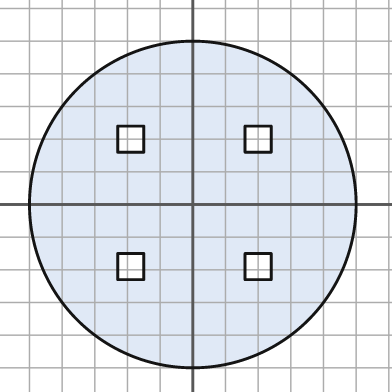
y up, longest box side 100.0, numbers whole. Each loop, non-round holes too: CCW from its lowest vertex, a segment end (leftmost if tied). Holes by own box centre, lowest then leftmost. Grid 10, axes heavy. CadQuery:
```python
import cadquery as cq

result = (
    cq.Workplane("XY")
    .moveTo(0.0, 0.0)
    .circle(50.0)
    .moveTo(-23.0, -23.0)
    .lineTo(-15.0, -23.0)
    .lineTo(-15.0, -15.0)
    .lineTo(-23.0, -15.0)
    .close()
    .moveTo(16.0, -23.0)
    .lineTo(24.0, -23.0)
    .lineTo(24.0, -15.0)
    .lineTo(16.0, -15.0)
    .close()
    .moveTo(-23.0, 16.0)
    .lineTo(-15.0, 16.0)
    .lineTo(-15.0, 24.0)
    .lineTo(-23.0, 24.0)
    .close()
    .moveTo(16.0, 16.0)
    .lineTo(24.0, 16.0)
    .lineTo(24.0, 24.0)
    .lineTo(16.0, 24.0)
    .close()
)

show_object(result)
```